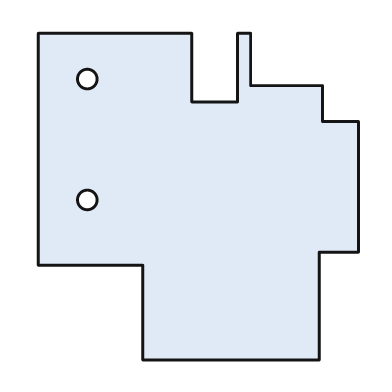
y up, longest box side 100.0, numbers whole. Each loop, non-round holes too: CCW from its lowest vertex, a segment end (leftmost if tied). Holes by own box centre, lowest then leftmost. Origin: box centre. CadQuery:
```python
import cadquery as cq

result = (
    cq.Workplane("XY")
    .moveTo(-17.0, -50.0)
    .lineTo(37.0, -50.0)
    .lineTo(37.0, -17.0)
    .lineTo(49.0, -17.0)
    .lineTo(49.0, 23.0)
    .lineTo(38.0, 23.0)
    .lineTo(38.0, 34.0)
    .lineTo(16.0, 34.0)
    .lineTo(16.0, 50.0)
    .lineTo(12.0, 50.0)
    .lineTo(12.0, 29.0)
    .lineTo(-2.0, 29.0)
    .lineTo(-2.0, 50.0)
    .lineTo(-49.0, 50.0)
    .lineTo(-49.0, -21.0)
    .lineTo(-17.0, -21.0)
    .close()
    .moveTo(-34.0, -1.0)
    .circle(3.0)
    .moveTo(-34.0, 36.0)
    .circle(3.0)
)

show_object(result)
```